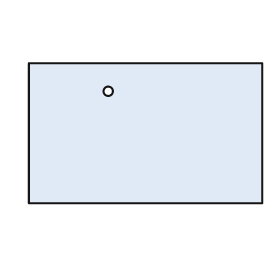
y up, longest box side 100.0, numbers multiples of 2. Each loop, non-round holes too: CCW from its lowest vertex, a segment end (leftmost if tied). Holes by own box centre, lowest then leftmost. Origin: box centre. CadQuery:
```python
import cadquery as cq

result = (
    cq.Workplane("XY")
    .moveTo(-50.0, -30.0)
    .lineTo(50.0, -30.0)
    .lineTo(50.0, 30.0)
    .lineTo(-50.0, 30.0)
    .close()
    .moveTo(-16.0, 18.0)
    .circle(2.0)
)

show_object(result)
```